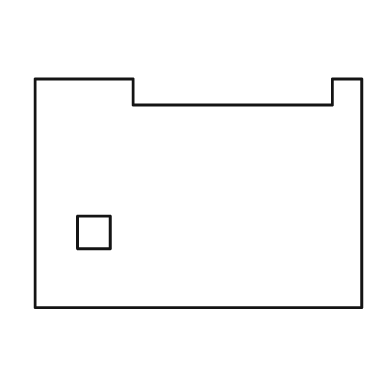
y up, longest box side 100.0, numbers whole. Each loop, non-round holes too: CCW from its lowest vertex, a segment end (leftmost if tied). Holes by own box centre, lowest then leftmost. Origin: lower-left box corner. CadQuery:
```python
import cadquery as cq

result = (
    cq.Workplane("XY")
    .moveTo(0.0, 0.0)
    .lineTo(100.0, 0.0)
    .lineTo(100.0, 70.0)
    .lineTo(91.0, 70.0)
    .lineTo(91.0, 62.0)
    .lineTo(30.0, 62.0)
    .lineTo(30.0, 70.0)
    .lineTo(0.0, 70.0)
    .close()
    .moveTo(13.0, 18.0)
    .lineTo(23.0, 18.0)
    .lineTo(23.0, 28.0)
    .lineTo(13.0, 28.0)
    .close()
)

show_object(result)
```